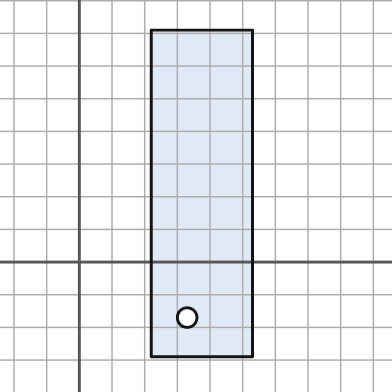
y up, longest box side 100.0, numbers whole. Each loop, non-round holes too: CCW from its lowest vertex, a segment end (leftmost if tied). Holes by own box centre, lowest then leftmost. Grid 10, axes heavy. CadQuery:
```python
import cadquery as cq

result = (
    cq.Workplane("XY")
    .moveTo(22.0, -29.0)
    .lineTo(53.0, -29.0)
    .lineTo(53.0, 71.0)
    .lineTo(22.0, 71.0)
    .close()
    .moveTo(33.0, -17.0)
    .circle(3.0)
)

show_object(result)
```